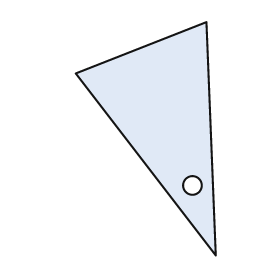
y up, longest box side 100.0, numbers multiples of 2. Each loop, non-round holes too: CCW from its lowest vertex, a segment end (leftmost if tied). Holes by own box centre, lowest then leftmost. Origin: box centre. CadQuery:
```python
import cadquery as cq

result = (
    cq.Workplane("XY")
    .moveTo(30.0, -50.0)
    .lineTo(26.0, 50.0)
    .lineTo(-30.0, 28.0)
    .close()
    .moveTo(20.0, -20.0)
    .circle(4.0)
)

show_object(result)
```